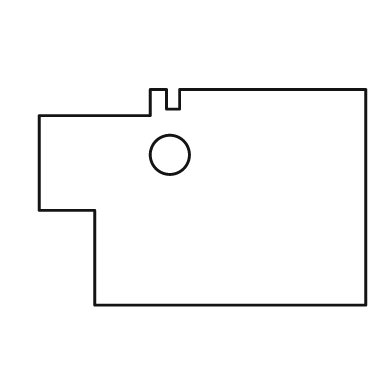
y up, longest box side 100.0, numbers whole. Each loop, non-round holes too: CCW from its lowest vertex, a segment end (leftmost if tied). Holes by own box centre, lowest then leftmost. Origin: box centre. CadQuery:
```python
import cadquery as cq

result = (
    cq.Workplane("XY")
    .moveTo(-33.0, -33.0)
    .lineTo(50.0, -33.0)
    .lineTo(50.0, 33.0)
    .lineTo(-7.0, 33.0)
    .lineTo(-7.0, 27.0)
    .lineTo(-11.0, 27.0)
    .lineTo(-11.0, 33.0)
    .lineTo(-16.0, 33.0)
    .lineTo(-16.0, 25.0)
    .lineTo(-50.0, 25.0)
    .lineTo(-50.0, -4.0)
    .lineTo(-33.0, -4.0)
    .close()
    .moveTo(-10.0, 13.0)
    .circle(6.0)
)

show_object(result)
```